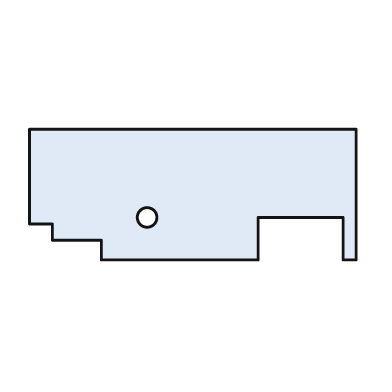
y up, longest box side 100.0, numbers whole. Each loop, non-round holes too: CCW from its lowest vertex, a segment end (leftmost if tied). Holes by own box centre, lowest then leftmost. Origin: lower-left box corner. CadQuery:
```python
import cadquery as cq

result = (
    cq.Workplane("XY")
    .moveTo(22.0, 0.0)
    .lineTo(70.0, 0.0)
    .lineTo(70.0, 13.0)
    .lineTo(96.0, 13.0)
    .lineTo(96.0, 0.0)
    .lineTo(100.0, 0.0)
    .lineTo(100.0, 40.0)
    .lineTo(0.0, 40.0)
    .lineTo(0.0, 11.0)
    .lineTo(7.0, 11.0)
    .lineTo(7.0, 6.0)
    .lineTo(22.0, 6.0)
    .close()
    .moveTo(36.0, 13.0)
    .circle(3.0)
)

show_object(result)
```